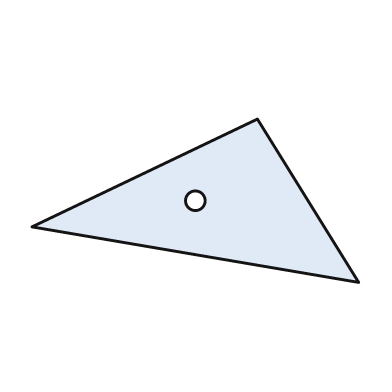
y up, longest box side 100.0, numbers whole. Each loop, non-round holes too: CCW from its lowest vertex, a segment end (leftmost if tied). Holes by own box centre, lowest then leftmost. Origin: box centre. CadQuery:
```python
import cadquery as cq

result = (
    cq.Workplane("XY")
    .moveTo(50.0, -25.0)
    .lineTo(19.0, 25.0)
    .lineTo(-50.0, -8.0)
    .close()
    .moveTo(0.0, 0.0)
    .circle(3.0)
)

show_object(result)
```